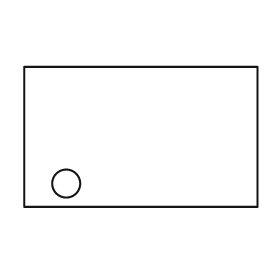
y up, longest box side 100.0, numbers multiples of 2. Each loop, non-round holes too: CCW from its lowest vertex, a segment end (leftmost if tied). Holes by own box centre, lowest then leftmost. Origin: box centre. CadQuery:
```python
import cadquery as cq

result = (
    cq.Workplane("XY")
    .moveTo(-50.0, -30.0)
    .lineTo(50.0, -30.0)
    .lineTo(50.0, 30.0)
    .lineTo(-50.0, 30.0)
    .close()
    .moveTo(-32.0, -20.0)
    .circle(6.0)
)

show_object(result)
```